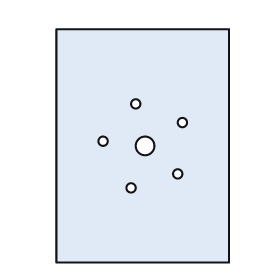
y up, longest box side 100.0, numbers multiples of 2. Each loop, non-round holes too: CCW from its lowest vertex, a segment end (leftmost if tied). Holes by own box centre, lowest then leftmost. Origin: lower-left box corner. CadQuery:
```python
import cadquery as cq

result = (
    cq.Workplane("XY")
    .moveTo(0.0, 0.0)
    .lineTo(74.0, 0.0)
    .lineTo(74.0, 100.0)
    .lineTo(0.0, 100.0)
    .close()
    .moveTo(32.0, 32.0)
    .circle(2.0)
    .moveTo(52.0, 38.0)
    .circle(2.0)
    .moveTo(38.0, 50.0)
    .circle(4.0)
    .moveTo(20.0, 52.0)
    .circle(2.0)
    .moveTo(54.0, 60.0)
    .circle(2.0)
    .moveTo(34.0, 68.0)
    .circle(2.0)
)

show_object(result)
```